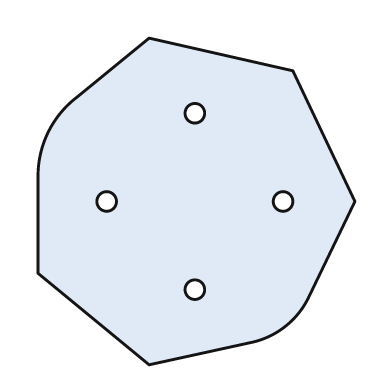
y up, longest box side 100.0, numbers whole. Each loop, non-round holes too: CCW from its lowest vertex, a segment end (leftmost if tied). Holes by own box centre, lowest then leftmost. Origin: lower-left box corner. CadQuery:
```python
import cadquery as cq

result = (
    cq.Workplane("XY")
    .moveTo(34.0, 0.0)
    .lineTo(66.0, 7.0)
    .threePointArc((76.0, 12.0), (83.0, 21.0))
    .lineTo(97.0, 50.0)
    .lineTo(78.0, 90.0)
    .lineTo(34.0, 100.0)
    .lineTo(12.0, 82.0)
    .threePointArc((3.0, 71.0), (0.0, 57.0))
    .lineTo(0.0, 28.0)
    .close()
    .moveTo(48.0, 23.0)
    .circle(3.0)
    .moveTo(21.0, 50.0)
    .circle(3.0)
    .moveTo(75.0, 50.0)
    .circle(3.0)
    .moveTo(48.0, 77.0)
    .circle(3.0)
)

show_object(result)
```